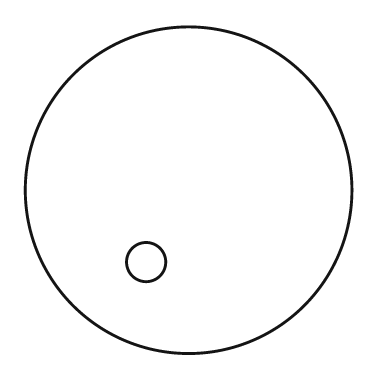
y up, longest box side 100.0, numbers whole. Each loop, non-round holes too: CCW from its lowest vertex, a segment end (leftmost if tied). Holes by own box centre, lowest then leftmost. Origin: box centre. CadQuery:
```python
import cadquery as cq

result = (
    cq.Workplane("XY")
    .moveTo(0.0, 0.0)
    .circle(50.0)
    .moveTo(-13.0, -22.0)
    .circle(6.0)
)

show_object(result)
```